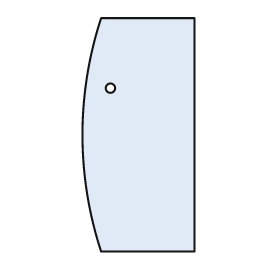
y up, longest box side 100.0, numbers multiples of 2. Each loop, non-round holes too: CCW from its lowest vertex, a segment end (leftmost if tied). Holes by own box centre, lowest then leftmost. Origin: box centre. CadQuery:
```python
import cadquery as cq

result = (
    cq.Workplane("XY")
    .moveTo(-16.0, -50.0)
    .lineTo(24.0, -50.0)
    .lineTo(24.0, 50.0)
    .lineTo(-16.0, 50.0)
    .threePointArc((-24.0, 0.0), (-16.0, -50.0))
    .close()
    .moveTo(-12.0, 20.0)
    .circle(2.0)
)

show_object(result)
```